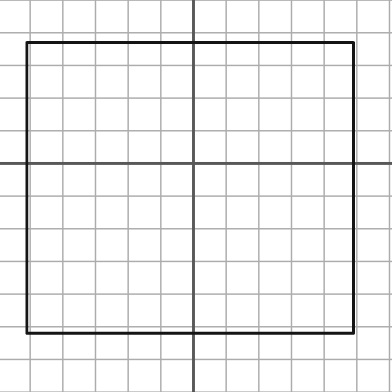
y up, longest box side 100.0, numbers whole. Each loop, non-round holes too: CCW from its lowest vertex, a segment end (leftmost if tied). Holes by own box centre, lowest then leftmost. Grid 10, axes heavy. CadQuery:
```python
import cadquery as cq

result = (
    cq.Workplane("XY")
    .moveTo(-51.0, -52.0)
    .lineTo(49.0, -52.0)
    .lineTo(49.0, 37.0)
    .lineTo(-51.0, 37.0)
    .close()
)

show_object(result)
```